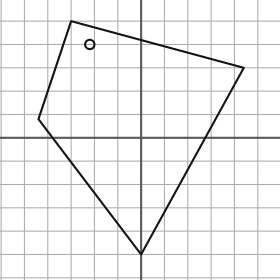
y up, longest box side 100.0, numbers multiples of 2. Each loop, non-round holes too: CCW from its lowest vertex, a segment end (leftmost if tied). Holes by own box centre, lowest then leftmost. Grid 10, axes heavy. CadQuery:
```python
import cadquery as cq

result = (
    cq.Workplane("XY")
    .moveTo(0.0, -50.0)
    .lineTo(44.0, 30.0)
    .lineTo(-30.0, 50.0)
    .lineTo(-44.0, 8.0)
    .close()
    .moveTo(-22.0, 40.0)
    .circle(2.0)
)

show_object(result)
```